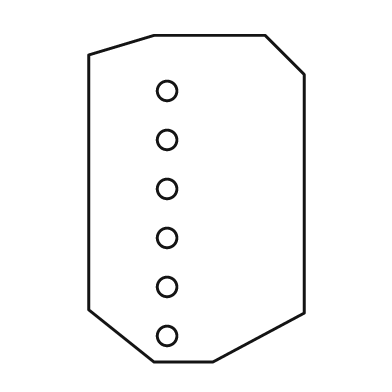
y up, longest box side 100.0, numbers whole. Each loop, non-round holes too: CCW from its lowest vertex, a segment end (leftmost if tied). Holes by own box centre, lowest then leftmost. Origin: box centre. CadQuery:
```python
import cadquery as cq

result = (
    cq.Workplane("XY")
    .moveTo(-13.0, -50.0)
    .lineTo(5.0, -50.0)
    .lineTo(33.0, -35.0)
    .lineTo(33.0, 38.0)
    .lineTo(21.0, 50.0)
    .lineTo(-13.0, 50.0)
    .lineTo(-33.0, 44.0)
    .lineTo(-33.0, -34.0)
    .close()
    .moveTo(-9.0, -42.0)
    .circle(3.0)
    .moveTo(-9.0, -27.0)
    .circle(3.0)
    .moveTo(-9.0, -12.0)
    .circle(3.0)
    .moveTo(-9.0, 3.0)
    .circle(3.0)
    .moveTo(-9.0, 18.0)
    .circle(3.0)
    .moveTo(-9.0, 33.0)
    .circle(3.0)
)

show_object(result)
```